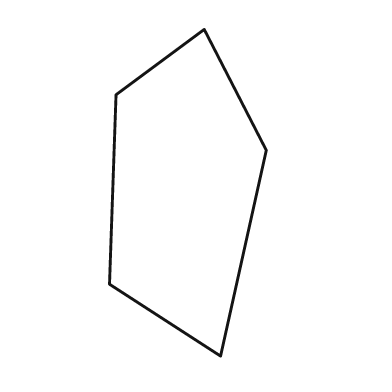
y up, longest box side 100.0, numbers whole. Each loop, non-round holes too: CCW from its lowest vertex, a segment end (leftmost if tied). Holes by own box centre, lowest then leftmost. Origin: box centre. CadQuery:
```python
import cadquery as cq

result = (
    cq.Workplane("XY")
    .moveTo(10.0, -50.0)
    .lineTo(24.0, 13.0)
    .lineTo(5.0, 50.0)
    .lineTo(-22.0, 30.0)
    .lineTo(-24.0, -28.0)
    .close()
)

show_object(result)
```